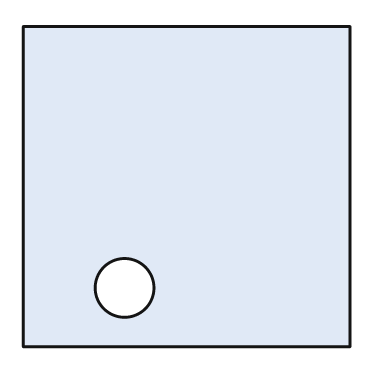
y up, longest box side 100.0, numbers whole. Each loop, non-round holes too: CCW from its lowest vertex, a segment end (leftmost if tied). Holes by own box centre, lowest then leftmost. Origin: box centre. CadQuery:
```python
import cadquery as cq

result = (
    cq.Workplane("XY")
    .moveTo(-50.0, -49.0)
    .lineTo(50.0, -49.0)
    .lineTo(50.0, 49.0)
    .lineTo(-50.0, 49.0)
    .close()
    .moveTo(-19.0, -31.0)
    .circle(9.0)
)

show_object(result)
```